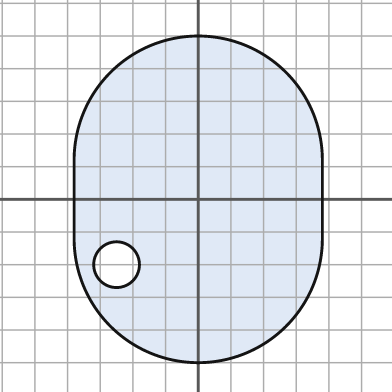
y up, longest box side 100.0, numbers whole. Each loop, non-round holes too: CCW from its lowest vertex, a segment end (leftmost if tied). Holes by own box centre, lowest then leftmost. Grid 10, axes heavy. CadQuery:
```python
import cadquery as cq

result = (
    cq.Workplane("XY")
    .moveTo(-38.0, -12.0)
    .threePointArc((0.0, -50.0), (38.0, -12.0))
    .lineTo(38.0, 12.0)
    .threePointArc((0.0, 50.0), (-38.0, 12.0))
    .close()
    .moveTo(-25.0, -20.0)
    .circle(7.0)
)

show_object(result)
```